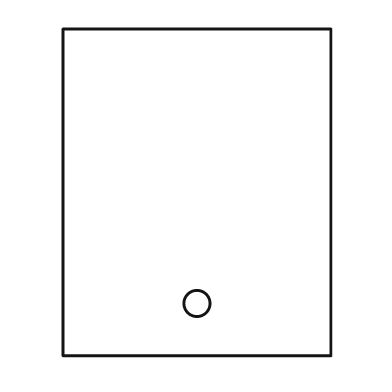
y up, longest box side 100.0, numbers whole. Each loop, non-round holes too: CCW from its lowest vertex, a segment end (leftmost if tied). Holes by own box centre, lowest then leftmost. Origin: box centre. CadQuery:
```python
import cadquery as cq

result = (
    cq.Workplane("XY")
    .moveTo(-41.0, -50.0)
    .lineTo(41.0, -50.0)
    .lineTo(41.0, 50.0)
    .lineTo(-41.0, 50.0)
    .close()
    .moveTo(0.0, -34.0)
    .circle(4.0)
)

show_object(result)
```